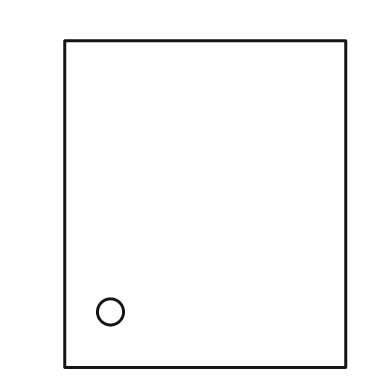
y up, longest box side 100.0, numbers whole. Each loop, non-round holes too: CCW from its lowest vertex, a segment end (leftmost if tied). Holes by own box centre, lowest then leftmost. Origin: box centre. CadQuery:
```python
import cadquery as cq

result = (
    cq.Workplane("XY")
    .moveTo(-43.0, -50.0)
    .lineTo(43.0, -50.0)
    .lineTo(43.0, 50.0)
    .lineTo(-43.0, 50.0)
    .close()
    .moveTo(-29.0, -33.0)
    .circle(4.0)
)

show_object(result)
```